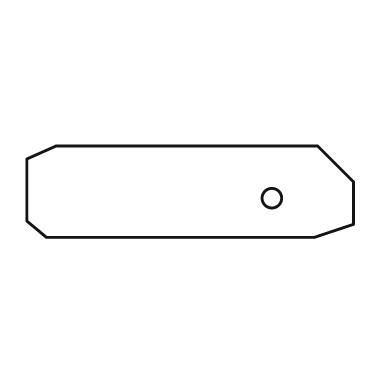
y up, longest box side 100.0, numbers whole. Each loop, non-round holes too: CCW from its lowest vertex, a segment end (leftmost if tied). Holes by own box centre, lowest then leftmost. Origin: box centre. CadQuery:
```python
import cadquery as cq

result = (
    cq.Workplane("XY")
    .moveTo(-44.0, -14.0)
    .lineTo(38.0, -14.0)
    .lineTo(50.0, -10.0)
    .lineTo(50.0, 3.0)
    .lineTo(39.0, 14.0)
    .lineTo(-41.0, 14.0)
    .lineTo(-50.0, 10.0)
    .lineTo(-50.0, -9.0)
    .close()
    .moveTo(25.0, -2.0)
    .circle(3.0)
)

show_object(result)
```